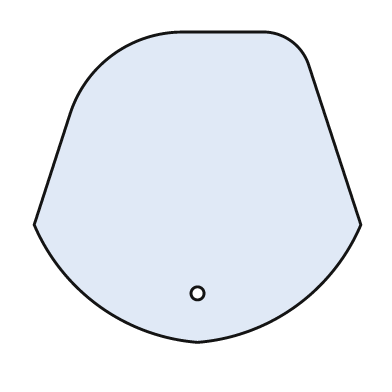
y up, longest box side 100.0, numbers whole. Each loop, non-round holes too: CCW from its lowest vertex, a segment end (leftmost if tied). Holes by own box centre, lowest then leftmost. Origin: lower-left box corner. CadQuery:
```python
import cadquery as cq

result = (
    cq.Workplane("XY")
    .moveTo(50.0, 0.0)
    .threePointArc((80.0, 11.0), (100.0, 36.0))
    .lineTo(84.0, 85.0)
    .threePointArc((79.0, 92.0), (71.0, 95.0))
    .lineTo(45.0, 95.0)
    .threePointArc((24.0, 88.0), (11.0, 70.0))
    .lineTo(0.0, 36.0)
    .threePointArc((20.0, 11.0), (50.0, 0.0))
    .close()
    .moveTo(50.0, 15.0)
    .circle(2.0)
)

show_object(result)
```